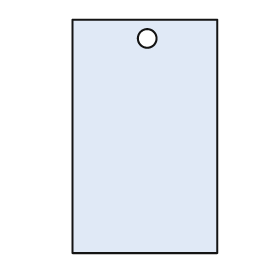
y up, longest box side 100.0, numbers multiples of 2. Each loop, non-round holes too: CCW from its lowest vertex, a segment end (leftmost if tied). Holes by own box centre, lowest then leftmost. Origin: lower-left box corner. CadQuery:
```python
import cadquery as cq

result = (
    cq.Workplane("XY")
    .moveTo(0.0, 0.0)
    .lineTo(62.0, 0.0)
    .lineTo(62.0, 100.0)
    .lineTo(0.0, 100.0)
    .close()
    .moveTo(32.0, 92.0)
    .circle(4.0)
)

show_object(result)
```